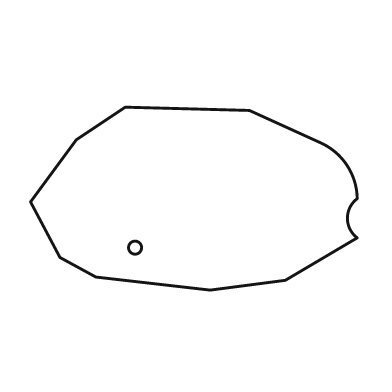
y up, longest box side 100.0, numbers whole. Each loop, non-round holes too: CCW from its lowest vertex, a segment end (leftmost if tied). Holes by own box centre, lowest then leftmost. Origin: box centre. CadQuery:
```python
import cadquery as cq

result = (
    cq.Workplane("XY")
    .moveTo(5.0, -28.0)
    .lineTo(28.0, -25.0)
    .lineTo(50.0, -12.0)
    .threePointArc((47.0, -6.0), (50.0, 0.0))
    .threePointArc((47.0, 10.0), (39.0, 17.0))
    .lineTo(17.0, 27.0)
    .lineTo(-21.0, 28.0)
    .lineTo(-36.0, 18.0)
    .lineTo(-50.0, -1.0)
    .lineTo(-41.0, -18.0)
    .lineTo(-30.0, -24.0)
    .close()
    .moveTo(-18.0, -15.0)
    .circle(2.0)
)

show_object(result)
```